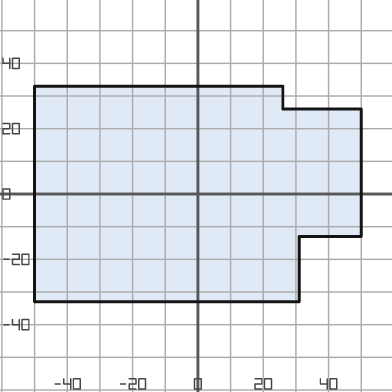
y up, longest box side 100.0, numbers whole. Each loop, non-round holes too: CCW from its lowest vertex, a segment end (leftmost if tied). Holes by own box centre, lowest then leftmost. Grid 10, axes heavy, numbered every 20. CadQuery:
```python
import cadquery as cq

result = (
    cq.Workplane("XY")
    .moveTo(-50.0, -33.0)
    .lineTo(31.0, -33.0)
    .lineTo(31.0, -13.0)
    .lineTo(50.0, -13.0)
    .lineTo(50.0, 26.0)
    .lineTo(26.0, 26.0)
    .lineTo(26.0, 33.0)
    .lineTo(-50.0, 33.0)
    .close()
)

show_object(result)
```